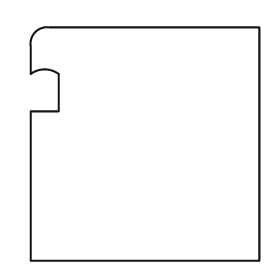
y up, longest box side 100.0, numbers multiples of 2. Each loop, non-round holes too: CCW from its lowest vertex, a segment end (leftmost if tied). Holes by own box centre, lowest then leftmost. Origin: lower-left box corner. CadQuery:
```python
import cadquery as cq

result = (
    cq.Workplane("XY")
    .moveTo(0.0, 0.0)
    .lineTo(98.0, 0.0)
    .lineTo(98.0, 100.0)
    .lineTo(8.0, 100.0)
    .threePointArc((2.0, 98.0), (0.0, 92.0))
    .lineTo(0.0, 80.0)
    .threePointArc((6.0, 82.0), (12.0, 80.0))
    .lineTo(12.0, 64.0)
    .lineTo(0.0, 64.0)
    .close()
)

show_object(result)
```